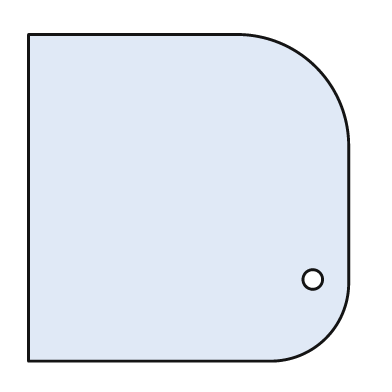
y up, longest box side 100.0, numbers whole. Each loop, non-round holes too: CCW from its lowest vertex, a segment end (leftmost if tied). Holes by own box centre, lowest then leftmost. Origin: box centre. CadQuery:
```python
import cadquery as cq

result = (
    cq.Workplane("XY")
    .moveTo(-49.0, -50.0)
    .lineTo(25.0, -50.0)
    .threePointArc((42.0, -43.0), (49.0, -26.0))
    .lineTo(49.0, 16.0)
    .threePointArc((39.0, 40.0), (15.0, 50.0))
    .lineTo(-49.0, 50.0)
    .close()
    .moveTo(38.0, -25.0)
    .circle(3.0)
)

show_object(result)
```